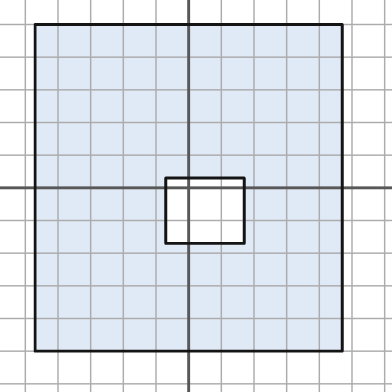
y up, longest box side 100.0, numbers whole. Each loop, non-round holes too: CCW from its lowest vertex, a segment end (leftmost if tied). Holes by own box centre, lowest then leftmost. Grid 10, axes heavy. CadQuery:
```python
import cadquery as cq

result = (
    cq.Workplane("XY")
    .moveTo(-47.0, -50.0)
    .lineTo(47.0, -50.0)
    .lineTo(47.0, 50.0)
    .lineTo(-47.0, 50.0)
    .close()
    .moveTo(-7.0, -17.0)
    .lineTo(17.0, -17.0)
    .lineTo(17.0, 3.0)
    .lineTo(-7.0, 3.0)
    .close()
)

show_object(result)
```